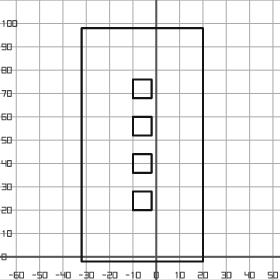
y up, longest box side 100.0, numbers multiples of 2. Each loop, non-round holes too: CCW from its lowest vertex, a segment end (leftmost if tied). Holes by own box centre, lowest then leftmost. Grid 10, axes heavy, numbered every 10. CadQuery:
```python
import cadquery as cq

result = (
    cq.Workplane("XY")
    .moveTo(-32.0, -2.0)
    .lineTo(20.0, -2.0)
    .lineTo(20.0, 98.0)
    .lineTo(-32.0, 98.0)
    .close()
    .moveTo(-10.0, 20.0)
    .lineTo(-2.0, 20.0)
    .lineTo(-2.0, 28.0)
    .lineTo(-10.0, 28.0)
    .close()
    .moveTo(-10.0, 36.0)
    .lineTo(-2.0, 36.0)
    .lineTo(-2.0, 44.0)
    .lineTo(-10.0, 44.0)
    .close()
    .moveTo(-10.0, 52.0)
    .lineTo(-2.0, 52.0)
    .lineTo(-2.0, 60.0)
    .lineTo(-10.0, 60.0)
    .close()
    .moveTo(-10.0, 68.0)
    .lineTo(-2.0, 68.0)
    .lineTo(-2.0, 76.0)
    .lineTo(-10.0, 76.0)
    .close()
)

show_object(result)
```